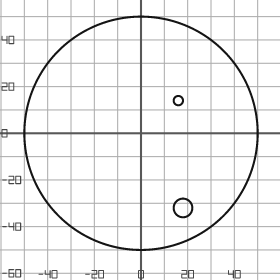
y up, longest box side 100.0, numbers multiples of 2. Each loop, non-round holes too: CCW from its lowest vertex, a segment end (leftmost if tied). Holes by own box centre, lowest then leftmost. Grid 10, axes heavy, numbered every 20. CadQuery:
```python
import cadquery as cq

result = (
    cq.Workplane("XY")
    .moveTo(0.0, 0.0)
    .circle(50.0)
    .moveTo(18.0, -32.0)
    .circle(4.0)
    .moveTo(16.0, 14.0)
    .circle(2.0)
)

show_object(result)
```